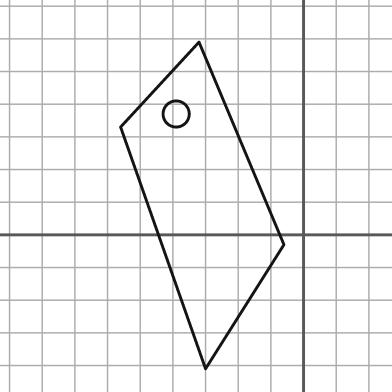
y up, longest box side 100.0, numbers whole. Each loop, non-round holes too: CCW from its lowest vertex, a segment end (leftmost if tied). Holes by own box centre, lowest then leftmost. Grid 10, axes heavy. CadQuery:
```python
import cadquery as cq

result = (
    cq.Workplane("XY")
    .moveTo(-30.0, -41.0)
    .lineTo(-6.0, -3.0)
    .lineTo(-32.0, 59.0)
    .lineTo(-56.0, 33.0)
    .close()
    .moveTo(-39.0, 37.0)
    .circle(4.0)
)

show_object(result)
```